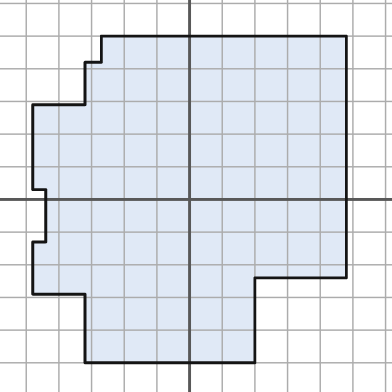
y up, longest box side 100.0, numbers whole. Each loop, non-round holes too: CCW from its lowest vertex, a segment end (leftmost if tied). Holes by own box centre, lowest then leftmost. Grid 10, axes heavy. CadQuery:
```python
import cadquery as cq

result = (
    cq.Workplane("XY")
    .moveTo(-32.0, -50.0)
    .lineTo(20.0, -50.0)
    .lineTo(20.0, -24.0)
    .lineTo(48.0, -24.0)
    .lineTo(48.0, 50.0)
    .lineTo(-27.0, 50.0)
    .lineTo(-27.0, 42.0)
    .lineTo(-32.0, 42.0)
    .lineTo(-32.0, 29.0)
    .lineTo(-48.0, 29.0)
    .lineTo(-48.0, 3.0)
    .lineTo(-44.0, 3.0)
    .lineTo(-44.0, -13.0)
    .lineTo(-48.0, -13.0)
    .lineTo(-48.0, -29.0)
    .lineTo(-32.0, -29.0)
    .close()
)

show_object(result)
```